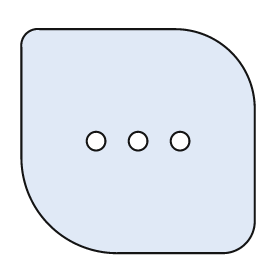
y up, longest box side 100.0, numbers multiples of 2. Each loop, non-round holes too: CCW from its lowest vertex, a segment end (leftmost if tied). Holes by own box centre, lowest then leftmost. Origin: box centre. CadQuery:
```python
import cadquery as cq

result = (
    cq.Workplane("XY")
    .moveTo(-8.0, -48.0)
    .lineTo(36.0, -48.0)
    .threePointArc((46.0, -44.0), (50.0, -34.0))
    .lineTo(50.0, 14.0)
    .threePointArc((40.0, 38.0), (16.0, 48.0))
    .lineTo(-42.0, 48.0)
    .threePointArc((-48.0, 46.0), (-50.0, 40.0))
    .lineTo(-50.0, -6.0)
    .threePointArc((-38.0, -36.0), (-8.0, -48.0))
    .close()
    .moveTo(-18.0, 0.0)
    .circle(4.0)
    .moveTo(0.0, 0.0)
    .circle(4.0)
    .moveTo(18.0, 0.0)
    .circle(4.0)
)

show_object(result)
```